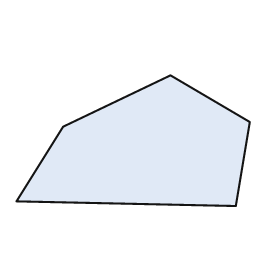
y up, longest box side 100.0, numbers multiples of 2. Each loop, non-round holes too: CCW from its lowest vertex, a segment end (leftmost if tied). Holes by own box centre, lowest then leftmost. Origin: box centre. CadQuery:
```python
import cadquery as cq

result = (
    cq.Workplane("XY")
    .moveTo(44.0, -28.0)
    .lineTo(50.0, 8.0)
    .lineTo(16.0, 28.0)
    .lineTo(-30.0, 6.0)
    .lineTo(-50.0, -26.0)
    .close()
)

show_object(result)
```